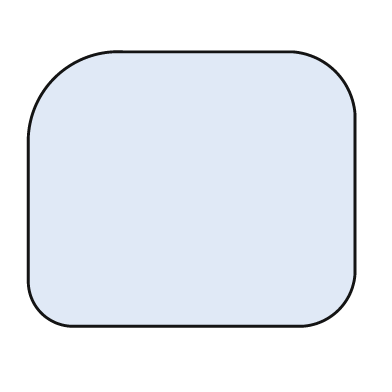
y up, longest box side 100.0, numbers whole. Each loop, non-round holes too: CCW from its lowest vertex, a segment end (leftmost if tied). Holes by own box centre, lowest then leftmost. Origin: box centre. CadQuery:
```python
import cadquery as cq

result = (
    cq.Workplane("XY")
    .moveTo(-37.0, -42.0)
    .lineTo(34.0, -42.0)
    .threePointArc((45.0, -37.0), (50.0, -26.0))
    .lineTo(50.0, 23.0)
    .threePointArc((44.0, 36.0), (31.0, 42.0))
    .lineTo(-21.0, 42.0)
    .threePointArc((-42.0, 34.0), (-50.0, 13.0))
    .lineTo(-50.0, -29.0)
    .threePointArc((-46.0, -38.0), (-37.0, -42.0))
    .close()
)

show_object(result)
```